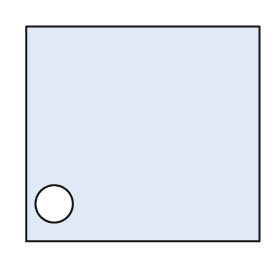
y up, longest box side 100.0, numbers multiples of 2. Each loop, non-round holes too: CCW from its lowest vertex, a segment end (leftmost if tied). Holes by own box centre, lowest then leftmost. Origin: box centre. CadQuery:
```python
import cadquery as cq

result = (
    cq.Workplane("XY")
    .moveTo(-50.0, -46.0)
    .lineTo(50.0, -46.0)
    .lineTo(50.0, 46.0)
    .lineTo(-50.0, 46.0)
    .close()
    .moveTo(-38.0, -30.0)
    .circle(8.0)
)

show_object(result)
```